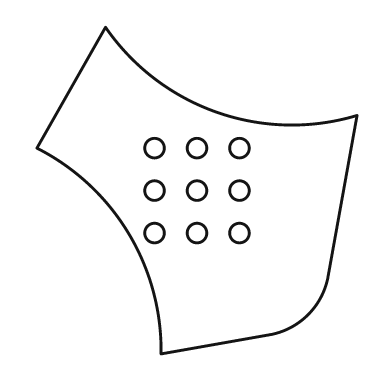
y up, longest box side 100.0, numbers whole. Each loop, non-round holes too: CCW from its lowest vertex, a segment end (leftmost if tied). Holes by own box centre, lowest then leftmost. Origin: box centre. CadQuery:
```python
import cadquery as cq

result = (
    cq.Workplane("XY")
    .moveTo(-11.0, -50.0)
    .lineTo(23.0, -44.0)
    .threePointArc((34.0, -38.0), (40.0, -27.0))
    .lineTo(49.0, 23.0)
    .threePointArc((6.0, 24.0), (-28.0, 50.0))
    .lineTo(-49.0, 13.0)
    .threePointArc((-21.0, -13.0), (-11.0, -50.0))
    .close()
    .moveTo(-13.0, -13.0)
    .circle(3.0)
    .moveTo(0.0, -13.0)
    .circle(3.0)
    .moveTo(13.0, -13.0)
    .circle(3.0)
    .moveTo(-13.0, 0.0)
    .circle(3.0)
    .moveTo(0.0, 0.0)
    .circle(3.0)
    .moveTo(13.0, 0.0)
    .circle(3.0)
    .moveTo(-13.0, 13.0)
    .circle(3.0)
    .moveTo(0.0, 13.0)
    .circle(3.0)
    .moveTo(13.0, 13.0)
    .circle(3.0)
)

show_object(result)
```